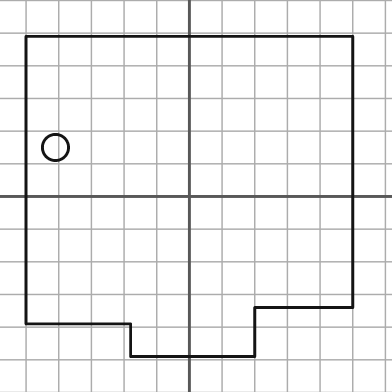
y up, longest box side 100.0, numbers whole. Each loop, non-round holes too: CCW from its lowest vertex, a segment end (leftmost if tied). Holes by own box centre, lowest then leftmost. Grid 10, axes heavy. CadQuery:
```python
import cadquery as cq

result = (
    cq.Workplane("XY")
    .moveTo(-18.0, -49.0)
    .lineTo(20.0, -49.0)
    .lineTo(20.0, -34.0)
    .lineTo(50.0, -34.0)
    .lineTo(50.0, 49.0)
    .lineTo(-50.0, 49.0)
    .lineTo(-50.0, -39.0)
    .lineTo(-18.0, -39.0)
    .close()
    .moveTo(-41.0, 15.0)
    .circle(4.0)
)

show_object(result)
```